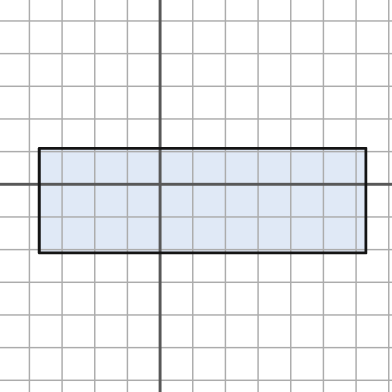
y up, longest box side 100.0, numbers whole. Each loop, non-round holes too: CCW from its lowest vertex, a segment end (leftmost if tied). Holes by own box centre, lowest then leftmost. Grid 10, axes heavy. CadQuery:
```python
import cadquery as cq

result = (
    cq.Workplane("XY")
    .moveTo(-37.0, -21.0)
    .lineTo(63.0, -21.0)
    .lineTo(63.0, 11.0)
    .lineTo(-37.0, 11.0)
    .close()
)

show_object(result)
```